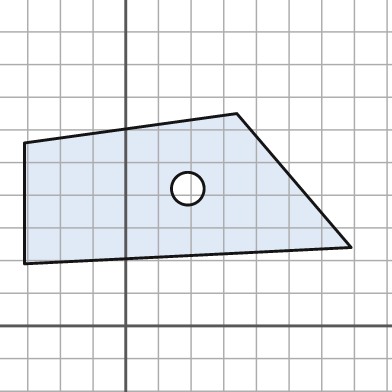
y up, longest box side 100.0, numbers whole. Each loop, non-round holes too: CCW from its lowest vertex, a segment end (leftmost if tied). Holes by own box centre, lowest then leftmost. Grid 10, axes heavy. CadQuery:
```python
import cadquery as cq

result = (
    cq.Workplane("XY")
    .moveTo(-31.0, 19.0)
    .lineTo(69.0, 24.0)
    .lineTo(34.0, 65.0)
    .lineTo(-31.0, 56.0)
    .close()
    .moveTo(19.0, 42.0)
    .circle(5.0)
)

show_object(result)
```